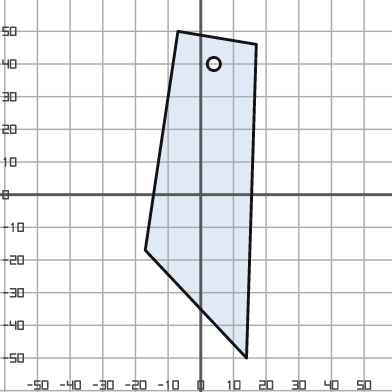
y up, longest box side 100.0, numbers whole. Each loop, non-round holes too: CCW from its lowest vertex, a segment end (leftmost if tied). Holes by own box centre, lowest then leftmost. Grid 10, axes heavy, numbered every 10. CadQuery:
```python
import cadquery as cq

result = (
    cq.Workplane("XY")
    .moveTo(14.0, -50.0)
    .lineTo(17.0, 46.0)
    .lineTo(-7.0, 50.0)
    .lineTo(-17.0, -17.0)
    .close()
    .moveTo(4.0, 40.0)
    .circle(2.0)
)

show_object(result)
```